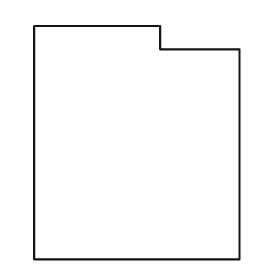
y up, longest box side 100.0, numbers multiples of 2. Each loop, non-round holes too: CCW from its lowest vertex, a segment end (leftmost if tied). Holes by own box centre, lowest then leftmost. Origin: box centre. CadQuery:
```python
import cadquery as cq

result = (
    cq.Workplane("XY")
    .moveTo(-44.0, -50.0)
    .lineTo(44.0, -50.0)
    .lineTo(44.0, 40.0)
    .lineTo(10.0, 40.0)
    .lineTo(10.0, 50.0)
    .lineTo(-44.0, 50.0)
    .close()
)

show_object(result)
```